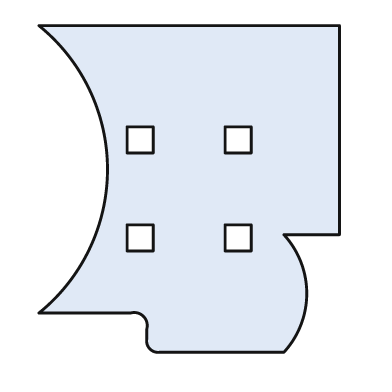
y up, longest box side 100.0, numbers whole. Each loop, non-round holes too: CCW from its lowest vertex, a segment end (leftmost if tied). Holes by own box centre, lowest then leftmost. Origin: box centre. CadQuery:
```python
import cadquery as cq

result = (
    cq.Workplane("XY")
    .moveTo(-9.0, -50.0)
    .lineTo(29.0, -50.0)
    .threePointArc((36.0, -32.0), (29.0, -14.0))
    .lineTo(46.0, -14.0)
    .lineTo(46.0, 50.0)
    .lineTo(-46.0, 50.0)
    .threePointArc((-25.0, 6.0), (-46.0, -38.0))
    .lineTo(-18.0, -38.0)
    .threePointArc((-14.0, -39.0), (-13.0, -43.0))
    .lineTo(-13.0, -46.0)
    .threePointArc((-12.0, -49.0), (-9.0, -50.0))
    .close()
    .moveTo(-19.0, -19.0)
    .lineTo(-11.0, -19.0)
    .lineTo(-11.0, -11.0)
    .lineTo(-19.0, -11.0)
    .close()
    .moveTo(11.0, -19.0)
    .lineTo(19.0, -19.0)
    .lineTo(19.0, -11.0)
    .lineTo(11.0, -11.0)
    .close()
    .moveTo(-19.0, 11.0)
    .lineTo(-11.0, 11.0)
    .lineTo(-11.0, 19.0)
    .lineTo(-19.0, 19.0)
    .close()
    .moveTo(11.0, 11.0)
    .lineTo(19.0, 11.0)
    .lineTo(19.0, 19.0)
    .lineTo(11.0, 19.0)
    .close()
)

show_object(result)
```